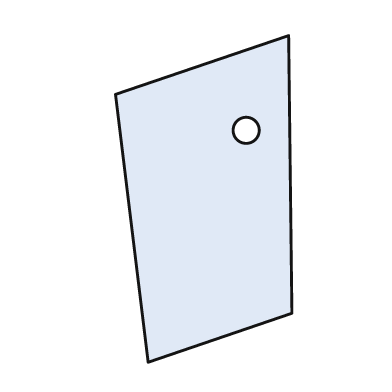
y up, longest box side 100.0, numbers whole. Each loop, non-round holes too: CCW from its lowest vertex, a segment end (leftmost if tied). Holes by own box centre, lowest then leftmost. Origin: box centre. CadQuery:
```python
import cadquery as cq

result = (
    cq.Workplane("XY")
    .moveTo(-17.0, -50.0)
    .lineTo(27.0, -35.0)
    .lineTo(26.0, 50.0)
    .lineTo(-27.0, 32.0)
    .close()
    .moveTo(13.0, 21.0)
    .circle(4.0)
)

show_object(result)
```